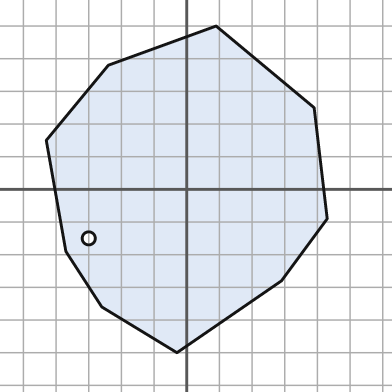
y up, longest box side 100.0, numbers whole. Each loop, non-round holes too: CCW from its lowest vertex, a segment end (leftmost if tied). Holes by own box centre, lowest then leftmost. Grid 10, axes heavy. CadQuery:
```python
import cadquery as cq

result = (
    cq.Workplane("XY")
    .moveTo(-3.0, -50.0)
    .lineTo(29.0, -28.0)
    .lineTo(43.0, -9.0)
    .lineTo(39.0, 25.0)
    .lineTo(9.0, 50.0)
    .lineTo(-24.0, 38.0)
    .lineTo(-43.0, 15.0)
    .lineTo(-37.0, -19.0)
    .lineTo(-26.0, -36.0)
    .close()
    .moveTo(-30.0, -15.0)
    .circle(2.0)
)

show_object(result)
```